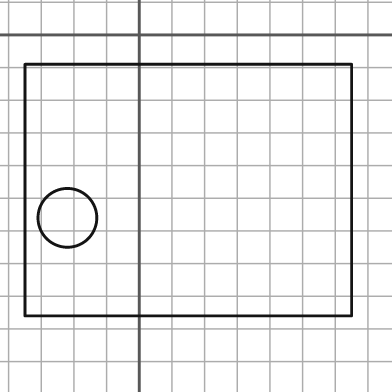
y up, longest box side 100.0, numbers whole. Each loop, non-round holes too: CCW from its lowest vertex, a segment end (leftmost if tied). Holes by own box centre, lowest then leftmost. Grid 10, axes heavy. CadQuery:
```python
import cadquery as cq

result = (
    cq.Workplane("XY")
    .moveTo(-35.0, -86.0)
    .lineTo(65.0, -86.0)
    .lineTo(65.0, -9.0)
    .lineTo(-35.0, -9.0)
    .close()
    .moveTo(-22.0, -56.0)
    .circle(9.0)
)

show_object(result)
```